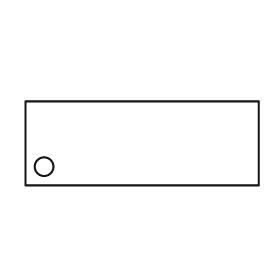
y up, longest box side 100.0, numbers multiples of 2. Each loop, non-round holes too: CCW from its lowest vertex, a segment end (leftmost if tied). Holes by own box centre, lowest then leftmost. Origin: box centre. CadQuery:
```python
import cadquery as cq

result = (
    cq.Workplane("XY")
    .moveTo(-50.0, -18.0)
    .lineTo(50.0, -18.0)
    .lineTo(50.0, 18.0)
    .lineTo(-50.0, 18.0)
    .close()
    .moveTo(-42.0, -10.0)
    .circle(4.0)
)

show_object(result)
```